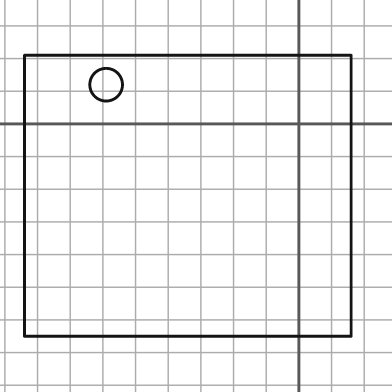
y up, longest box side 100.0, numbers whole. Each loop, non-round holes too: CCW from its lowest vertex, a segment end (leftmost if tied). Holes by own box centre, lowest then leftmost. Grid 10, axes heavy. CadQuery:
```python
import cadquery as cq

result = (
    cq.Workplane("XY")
    .moveTo(-84.0, -65.0)
    .lineTo(16.0, -65.0)
    .lineTo(16.0, 21.0)
    .lineTo(-84.0, 21.0)
    .close()
    .moveTo(-59.0, 12.0)
    .circle(5.0)
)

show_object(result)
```